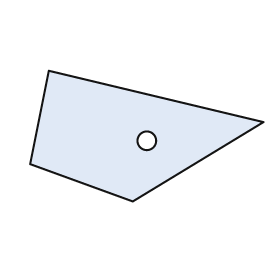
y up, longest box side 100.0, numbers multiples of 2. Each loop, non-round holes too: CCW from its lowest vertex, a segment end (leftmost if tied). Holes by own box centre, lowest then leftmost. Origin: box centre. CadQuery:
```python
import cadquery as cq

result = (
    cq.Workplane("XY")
    .moveTo(-6.0, -28.0)
    .lineTo(50.0, 6.0)
    .lineTo(-42.0, 28.0)
    .lineTo(-50.0, -12.0)
    .close()
    .moveTo(0.0, -2.0)
    .circle(4.0)
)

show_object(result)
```